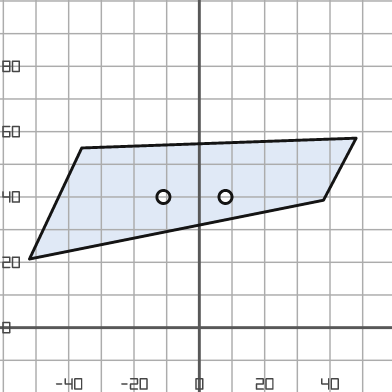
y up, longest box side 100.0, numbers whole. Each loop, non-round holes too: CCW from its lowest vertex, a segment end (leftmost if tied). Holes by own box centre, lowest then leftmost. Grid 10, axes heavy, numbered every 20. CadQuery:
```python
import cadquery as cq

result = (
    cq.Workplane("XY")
    .moveTo(-52.0, 21.0)
    .lineTo(38.0, 39.0)
    .lineTo(48.0, 58.0)
    .lineTo(-36.0, 55.0)
    .close()
    .moveTo(-11.0, 40.0)
    .circle(2.0)
    .moveTo(8.0, 40.0)
    .circle(2.0)
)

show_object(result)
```